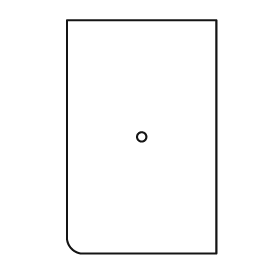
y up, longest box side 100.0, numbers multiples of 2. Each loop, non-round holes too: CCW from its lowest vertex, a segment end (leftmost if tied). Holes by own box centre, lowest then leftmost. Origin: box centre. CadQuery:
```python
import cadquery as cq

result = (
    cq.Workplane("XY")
    .moveTo(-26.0, -50.0)
    .lineTo(32.0, -50.0)
    .lineTo(32.0, 50.0)
    .lineTo(-32.0, 50.0)
    .lineTo(-32.0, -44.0)
    .threePointArc((-30.0, -48.0), (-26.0, -50.0))
    .close()
    .moveTo(0.0, 0.0)
    .circle(2.0)
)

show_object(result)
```